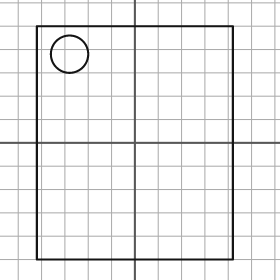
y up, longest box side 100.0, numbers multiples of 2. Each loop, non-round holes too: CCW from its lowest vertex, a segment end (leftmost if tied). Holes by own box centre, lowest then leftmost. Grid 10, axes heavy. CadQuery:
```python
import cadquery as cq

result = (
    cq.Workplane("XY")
    .moveTo(-42.0, -50.0)
    .lineTo(42.0, -50.0)
    .lineTo(42.0, 50.0)
    .lineTo(-42.0, 50.0)
    .close()
    .moveTo(-28.0, 38.0)
    .circle(8.0)
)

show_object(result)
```